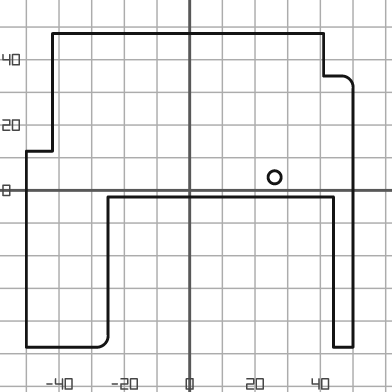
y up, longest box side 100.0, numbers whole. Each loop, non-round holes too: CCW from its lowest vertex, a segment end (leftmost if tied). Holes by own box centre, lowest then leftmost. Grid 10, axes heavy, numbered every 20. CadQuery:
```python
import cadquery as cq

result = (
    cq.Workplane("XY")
    .moveTo(-50.0, -48.0)
    .lineTo(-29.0, -48.0)
    .threePointArc((-26.0, -47.0), (-25.0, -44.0))
    .lineTo(-25.0, -2.0)
    .lineTo(44.0, -2.0)
    .lineTo(44.0, -48.0)
    .lineTo(50.0, -48.0)
    .lineTo(50.0, 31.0)
    .threePointArc((49.0, 34.0), (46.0, 35.0))
    .lineTo(41.0, 35.0)
    .lineTo(41.0, 48.0)
    .lineTo(-42.0, 48.0)
    .lineTo(-42.0, 12.0)
    .lineTo(-50.0, 12.0)
    .close()
    .moveTo(26.0, 4.0)
    .circle(2.0)
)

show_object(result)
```